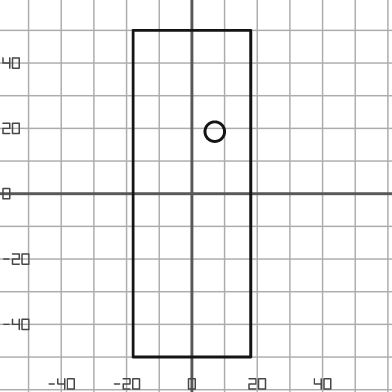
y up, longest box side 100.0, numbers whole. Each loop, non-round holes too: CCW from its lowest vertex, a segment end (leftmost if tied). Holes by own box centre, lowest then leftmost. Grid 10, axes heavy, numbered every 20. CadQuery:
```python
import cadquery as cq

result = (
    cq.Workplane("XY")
    .moveTo(-18.0, -50.0)
    .lineTo(18.0, -50.0)
    .lineTo(18.0, 50.0)
    .lineTo(-18.0, 50.0)
    .close()
    .moveTo(7.0, 19.0)
    .circle(3.0)
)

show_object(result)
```